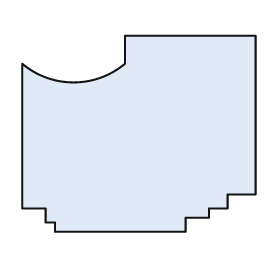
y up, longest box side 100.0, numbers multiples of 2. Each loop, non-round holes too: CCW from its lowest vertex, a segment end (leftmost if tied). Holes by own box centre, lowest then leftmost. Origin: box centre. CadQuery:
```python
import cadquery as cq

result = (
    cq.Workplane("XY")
    .moveTo(-36.0, -42.0)
    .lineTo(20.0, -42.0)
    .lineTo(20.0, -36.0)
    .lineTo(30.0, -36.0)
    .lineTo(30.0, -32.0)
    .lineTo(38.0, -32.0)
    .lineTo(38.0, -26.0)
    .lineTo(50.0, -26.0)
    .lineTo(50.0, 42.0)
    .lineTo(-6.0, 42.0)
    .lineTo(-6.0, 30.0)
    .threePointArc((-28.0, 22.0), (-50.0, 30.0))
    .lineTo(-50.0, -32.0)
    .lineTo(-40.0, -32.0)
    .lineTo(-40.0, -38.0)
    .lineTo(-36.0, -38.0)
    .close()
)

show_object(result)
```